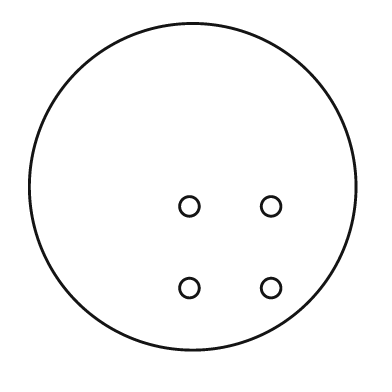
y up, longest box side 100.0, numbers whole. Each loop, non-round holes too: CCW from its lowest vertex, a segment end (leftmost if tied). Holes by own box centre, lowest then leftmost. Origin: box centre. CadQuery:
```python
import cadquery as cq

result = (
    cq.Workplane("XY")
    .moveTo(0.0, 0.0)
    .circle(50.0)
    .moveTo(-1.0, -31.0)
    .circle(3.0)
    .moveTo(24.0, -31.0)
    .circle(3.0)
    .moveTo(-1.0, -6.0)
    .circle(3.0)
    .moveTo(24.0, -6.0)
    .circle(3.0)
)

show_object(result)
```